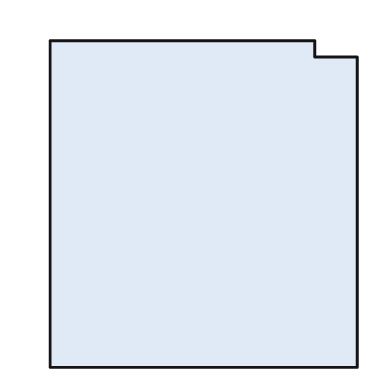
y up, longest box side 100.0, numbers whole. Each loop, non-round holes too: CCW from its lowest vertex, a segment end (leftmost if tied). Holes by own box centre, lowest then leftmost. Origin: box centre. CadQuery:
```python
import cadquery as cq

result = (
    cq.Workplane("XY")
    .moveTo(-47.0, -50.0)
    .lineTo(47.0, -50.0)
    .lineTo(47.0, 45.0)
    .lineTo(34.0, 45.0)
    .lineTo(34.0, 50.0)
    .lineTo(-47.0, 50.0)
    .close()
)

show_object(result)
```